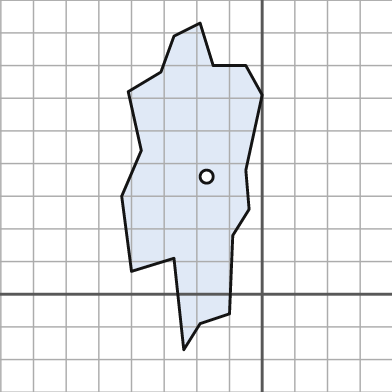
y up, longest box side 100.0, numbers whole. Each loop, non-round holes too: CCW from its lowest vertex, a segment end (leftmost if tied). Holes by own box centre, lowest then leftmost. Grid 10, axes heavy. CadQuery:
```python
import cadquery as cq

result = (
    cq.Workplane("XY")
    .moveTo(-24.0, -17.0)
    .lineTo(-19.0, -9.0)
    .lineTo(-10.0, -6.0)
    .lineTo(-9.0, 18.0)
    .lineTo(-4.0, 26.0)
    .lineTo(-5.0, 38.0)
    .lineTo(0.0, 61.0)
    .lineTo(-5.0, 70.0)
    .lineTo(-15.0, 70.0)
    .lineTo(-19.0, 83.0)
    .lineTo(-27.0, 79.0)
    .lineTo(-31.0, 68.0)
    .lineTo(-41.0, 62.0)
    .lineTo(-37.0, 44.0)
    .lineTo(-43.0, 30.0)
    .lineTo(-40.0, 7.0)
    .lineTo(-27.0, 11.0)
    .close()
    .moveTo(-17.0, 36.0)
    .circle(2.0)
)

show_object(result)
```